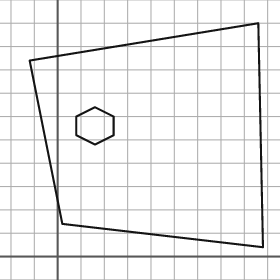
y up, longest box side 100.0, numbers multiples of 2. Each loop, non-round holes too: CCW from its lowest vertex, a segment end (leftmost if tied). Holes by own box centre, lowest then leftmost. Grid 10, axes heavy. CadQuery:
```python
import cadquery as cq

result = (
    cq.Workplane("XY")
    .moveTo(88.0, 4.0)
    .lineTo(86.0, 100.0)
    .lineTo(-12.0, 84.0)
    .lineTo(2.0, 14.0)
    .close()
    .moveTo(16.0, 48.0)
    .lineTo(24.0, 52.0)
    .lineTo(24.0, 60.0)
    .lineTo(16.0, 64.0)
    .lineTo(8.0, 60.0)
    .lineTo(8.0, 52.0)
    .close()
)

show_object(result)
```